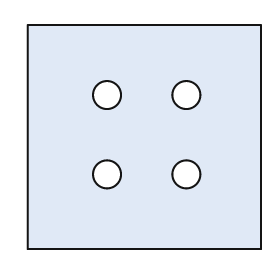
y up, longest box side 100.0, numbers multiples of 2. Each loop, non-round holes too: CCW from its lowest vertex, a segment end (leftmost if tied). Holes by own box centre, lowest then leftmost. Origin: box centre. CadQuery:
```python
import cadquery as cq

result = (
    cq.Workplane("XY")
    .moveTo(-50.0, -48.0)
    .lineTo(50.0, -48.0)
    .lineTo(50.0, 48.0)
    .lineTo(-50.0, 48.0)
    .close()
    .moveTo(-16.0, -16.0)
    .circle(6.0)
    .moveTo(18.0, -16.0)
    .circle(6.0)
    .moveTo(-16.0, 18.0)
    .circle(6.0)
    .moveTo(18.0, 18.0)
    .circle(6.0)
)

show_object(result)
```